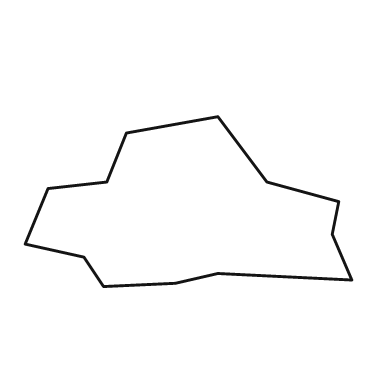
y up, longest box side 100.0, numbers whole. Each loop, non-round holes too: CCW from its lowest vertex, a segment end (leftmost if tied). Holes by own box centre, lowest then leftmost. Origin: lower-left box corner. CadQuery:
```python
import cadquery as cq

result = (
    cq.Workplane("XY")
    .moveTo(24.0, 0.0)
    .lineTo(46.0, 1.0)
    .lineTo(59.0, 4.0)
    .lineTo(100.0, 2.0)
    .lineTo(94.0, 16.0)
    .lineTo(96.0, 26.0)
    .lineTo(74.0, 32.0)
    .lineTo(59.0, 52.0)
    .lineTo(31.0, 47.0)
    .lineTo(25.0, 32.0)
    .lineTo(7.0, 30.0)
    .lineTo(0.0, 13.0)
    .lineTo(18.0, 9.0)
    .close()
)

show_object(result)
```